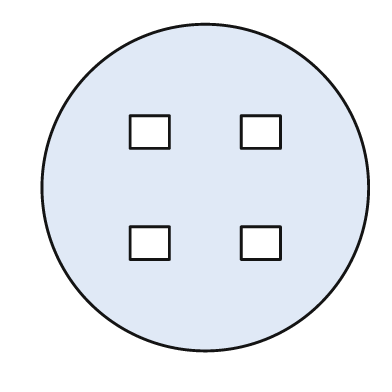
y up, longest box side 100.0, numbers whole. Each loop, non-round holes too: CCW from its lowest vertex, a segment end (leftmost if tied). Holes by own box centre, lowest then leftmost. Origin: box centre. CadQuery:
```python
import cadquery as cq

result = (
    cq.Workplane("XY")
    .moveTo(0.0, 0.0)
    .circle(50.0)
    .moveTo(-23.0, -22.0)
    .lineTo(-11.0, -22.0)
    .lineTo(-11.0, -12.0)
    .lineTo(-23.0, -12.0)
    .close()
    .moveTo(11.0, -22.0)
    .lineTo(23.0, -22.0)
    .lineTo(23.0, -12.0)
    .lineTo(11.0, -12.0)
    .close()
    .moveTo(-23.0, 12.0)
    .lineTo(-11.0, 12.0)
    .lineTo(-11.0, 22.0)
    .lineTo(-23.0, 22.0)
    .close()
    .moveTo(11.0, 12.0)
    .lineTo(23.0, 12.0)
    .lineTo(23.0, 22.0)
    .lineTo(11.0, 22.0)
    .close()
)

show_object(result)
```